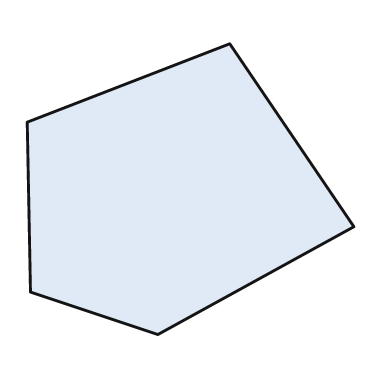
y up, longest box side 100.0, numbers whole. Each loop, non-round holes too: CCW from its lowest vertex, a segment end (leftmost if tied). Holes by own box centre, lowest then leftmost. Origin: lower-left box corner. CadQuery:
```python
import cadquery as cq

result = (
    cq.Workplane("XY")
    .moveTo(40.0, 0.0)
    .lineTo(100.0, 33.0)
    .lineTo(62.0, 89.0)
    .lineTo(0.0, 65.0)
    .lineTo(1.0, 13.0)
    .close()
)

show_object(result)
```